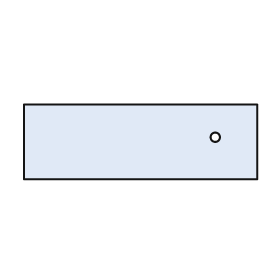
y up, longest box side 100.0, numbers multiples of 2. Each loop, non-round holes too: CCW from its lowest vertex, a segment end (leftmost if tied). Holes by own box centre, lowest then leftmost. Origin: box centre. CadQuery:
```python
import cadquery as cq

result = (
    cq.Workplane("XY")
    .moveTo(-50.0, -16.0)
    .lineTo(50.0, -16.0)
    .lineTo(50.0, 16.0)
    .lineTo(-50.0, 16.0)
    .close()
    .moveTo(32.0, 2.0)
    .circle(2.0)
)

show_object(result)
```